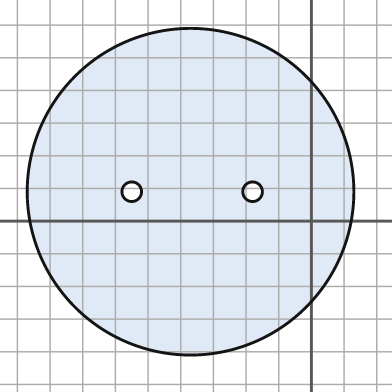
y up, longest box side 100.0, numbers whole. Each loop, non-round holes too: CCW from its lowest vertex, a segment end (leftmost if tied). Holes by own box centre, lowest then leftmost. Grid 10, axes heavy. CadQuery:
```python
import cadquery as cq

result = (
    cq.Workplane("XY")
    .moveTo(-37.0, 9.0)
    .circle(50.0)
    .moveTo(-55.0, 9.0)
    .circle(3.0)
    .moveTo(-18.0, 9.0)
    .circle(3.0)
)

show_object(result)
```